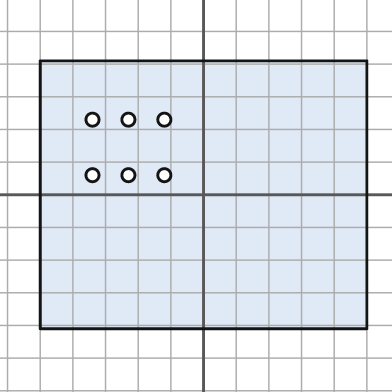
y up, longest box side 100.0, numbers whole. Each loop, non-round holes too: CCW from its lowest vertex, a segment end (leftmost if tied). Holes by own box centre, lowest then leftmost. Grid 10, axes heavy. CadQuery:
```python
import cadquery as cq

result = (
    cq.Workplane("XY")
    .moveTo(-50.0, -41.0)
    .lineTo(50.0, -41.0)
    .lineTo(50.0, 41.0)
    .lineTo(-50.0, 41.0)
    .close()
    .moveTo(-34.0, 6.0)
    .circle(2.0)
    .moveTo(-23.0, 6.0)
    .circle(2.0)
    .moveTo(-12.0, 6.0)
    .circle(2.0)
    .moveTo(-34.0, 23.0)
    .circle(2.0)
    .moveTo(-23.0, 23.0)
    .circle(2.0)
    .moveTo(-12.0, 23.0)
    .circle(2.0)
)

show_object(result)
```